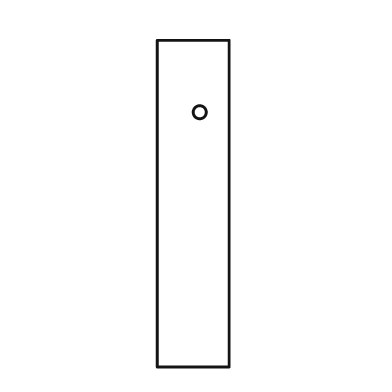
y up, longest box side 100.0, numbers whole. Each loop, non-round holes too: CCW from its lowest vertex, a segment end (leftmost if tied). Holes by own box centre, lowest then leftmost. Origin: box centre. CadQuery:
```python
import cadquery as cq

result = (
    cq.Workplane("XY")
    .moveTo(-11.0, -50.0)
    .lineTo(11.0, -50.0)
    .lineTo(11.0, 50.0)
    .lineTo(-11.0, 50.0)
    .close()
    .moveTo(2.0, 28.0)
    .circle(2.0)
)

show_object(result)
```